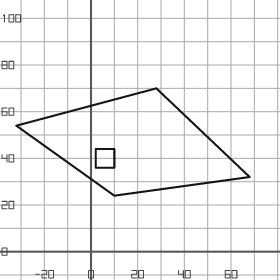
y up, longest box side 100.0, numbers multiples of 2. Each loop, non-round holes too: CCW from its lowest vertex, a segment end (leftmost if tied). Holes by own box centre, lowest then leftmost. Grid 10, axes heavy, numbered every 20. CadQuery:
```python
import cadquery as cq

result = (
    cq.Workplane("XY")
    .moveTo(10.0, 24.0)
    .lineTo(68.0, 32.0)
    .lineTo(28.0, 70.0)
    .lineTo(-32.0, 54.0)
    .close()
    .moveTo(2.0, 36.0)
    .lineTo(10.0, 36.0)
    .lineTo(10.0, 44.0)
    .lineTo(2.0, 44.0)
    .close()
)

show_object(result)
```